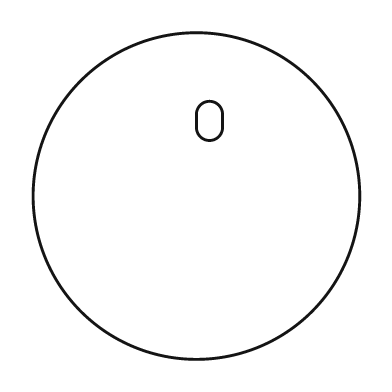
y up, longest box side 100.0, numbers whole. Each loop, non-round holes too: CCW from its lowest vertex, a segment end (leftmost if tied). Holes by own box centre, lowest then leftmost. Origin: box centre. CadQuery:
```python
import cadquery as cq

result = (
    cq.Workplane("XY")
    .moveTo(0.0, 0.0)
    .circle(50.0)
    .moveTo(0.0, 21.0)
    .threePointArc((4.0, 17.0), (8.0, 21.0))
    .lineTo(8.0, 25.0)
    .threePointArc((4.0, 29.0), (0.0, 25.0))
    .close()
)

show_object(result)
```